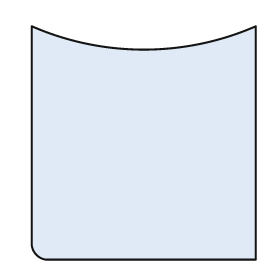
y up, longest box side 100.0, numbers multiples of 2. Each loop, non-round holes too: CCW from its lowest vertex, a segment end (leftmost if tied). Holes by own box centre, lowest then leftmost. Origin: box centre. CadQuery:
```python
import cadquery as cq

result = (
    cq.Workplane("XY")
    .moveTo(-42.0, -50.0)
    .lineTo(48.0, -50.0)
    .lineTo(48.0, 50.0)
    .threePointArc((0.0, 40.0), (-48.0, 50.0))
    .lineTo(-48.0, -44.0)
    .threePointArc((-46.0, -48.0), (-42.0, -50.0))
    .close()
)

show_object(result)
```